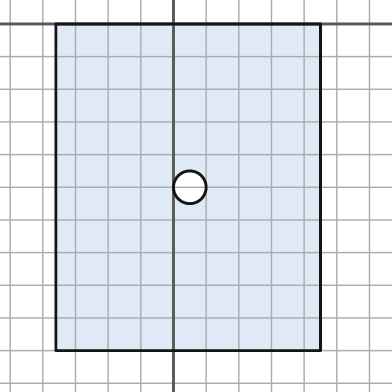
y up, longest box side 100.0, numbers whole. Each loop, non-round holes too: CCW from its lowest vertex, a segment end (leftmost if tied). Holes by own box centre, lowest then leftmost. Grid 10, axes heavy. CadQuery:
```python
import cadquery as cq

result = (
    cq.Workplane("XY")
    .moveTo(-36.0, -100.0)
    .lineTo(45.0, -100.0)
    .lineTo(45.0, 0.0)
    .lineTo(-36.0, 0.0)
    .close()
    .moveTo(5.0, -50.0)
    .circle(5.0)
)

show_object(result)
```